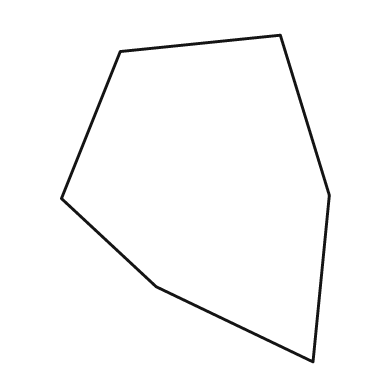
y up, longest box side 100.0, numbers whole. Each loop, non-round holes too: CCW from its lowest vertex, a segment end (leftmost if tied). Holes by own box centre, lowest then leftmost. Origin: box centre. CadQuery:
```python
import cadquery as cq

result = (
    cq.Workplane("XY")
    .moveTo(36.0, -50.0)
    .lineTo(41.0, 1.0)
    .lineTo(26.0, 50.0)
    .lineTo(-23.0, 45.0)
    .lineTo(-41.0, 0.0)
    .lineTo(-12.0, -27.0)
    .close()
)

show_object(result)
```